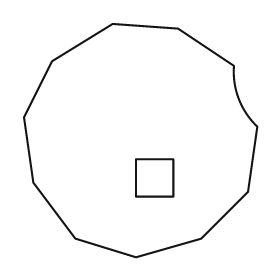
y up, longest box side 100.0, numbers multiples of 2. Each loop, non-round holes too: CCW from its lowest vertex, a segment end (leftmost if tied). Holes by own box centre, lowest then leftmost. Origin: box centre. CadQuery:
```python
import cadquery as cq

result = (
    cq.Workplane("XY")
    .moveTo(-2.0, -50.0)
    .lineTo(26.0, -42.0)
    .lineTo(46.0, -22.0)
    .lineTo(50.0, 6.0)
    .threePointArc((42.0, 18.0), (40.0, 32.0))
    .lineTo(16.0, 48.0)
    .lineTo(-12.0, 50.0)
    .lineTo(-38.0, 34.0)
    .lineTo(-50.0, 10.0)
    .lineTo(-46.0, -18.0)
    .lineTo(-28.0, -42.0)
    .close()
    .moveTo(-2.0, -24.0)
    .lineTo(14.0, -24.0)
    .lineTo(14.0, -8.0)
    .lineTo(-2.0, -8.0)
    .close()
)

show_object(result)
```